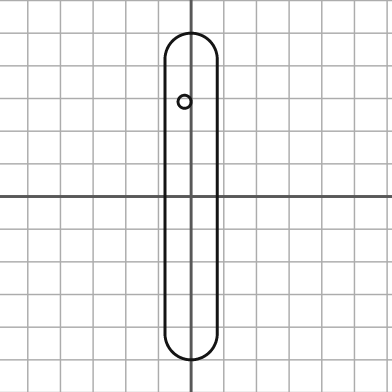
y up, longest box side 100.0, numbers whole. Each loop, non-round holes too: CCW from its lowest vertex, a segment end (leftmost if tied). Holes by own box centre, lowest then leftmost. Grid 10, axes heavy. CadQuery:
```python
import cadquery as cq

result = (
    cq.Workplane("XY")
    .moveTo(-8.0, -42.0)
    .threePointArc((0.0, -50.0), (8.0, -42.0))
    .lineTo(8.0, 42.0)
    .threePointArc((0.0, 50.0), (-8.0, 42.0))
    .close()
    .moveTo(-2.0, 29.0)
    .circle(2.0)
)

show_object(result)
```